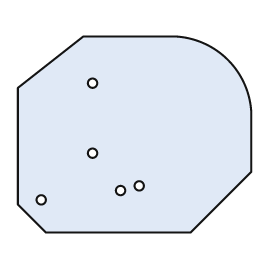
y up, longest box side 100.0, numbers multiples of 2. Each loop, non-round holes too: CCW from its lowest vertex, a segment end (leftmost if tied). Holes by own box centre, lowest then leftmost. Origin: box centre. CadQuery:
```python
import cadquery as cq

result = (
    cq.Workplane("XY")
    .moveTo(-38.0, -42.0)
    .lineTo(24.0, -42.0)
    .lineTo(50.0, -16.0)
    .lineTo(50.0, 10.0)
    .threePointArc((40.0, 32.0), (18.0, 42.0))
    .lineTo(-22.0, 42.0)
    .lineTo(-50.0, 20.0)
    .lineTo(-50.0, -30.0)
    .close()
    .moveTo(-40.0, -28.0)
    .circle(2.0)
    .moveTo(-6.0, -24.0)
    .circle(2.0)
    .moveTo(2.0, -22.0)
    .circle(2.0)
    .moveTo(-18.0, -8.0)
    .circle(2.0)
    .moveTo(-18.0, 22.0)
    .circle(2.0)
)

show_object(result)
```